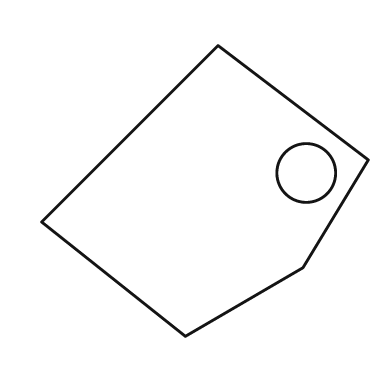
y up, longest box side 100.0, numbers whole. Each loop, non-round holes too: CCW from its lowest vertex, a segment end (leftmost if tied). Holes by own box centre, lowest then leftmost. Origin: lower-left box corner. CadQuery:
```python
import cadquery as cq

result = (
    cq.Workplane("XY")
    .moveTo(44.0, 0.0)
    .lineTo(80.0, 21.0)
    .lineTo(100.0, 54.0)
    .lineTo(54.0, 89.0)
    .lineTo(0.0, 35.0)
    .close()
    .moveTo(81.0, 50.0)
    .circle(9.0)
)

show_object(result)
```